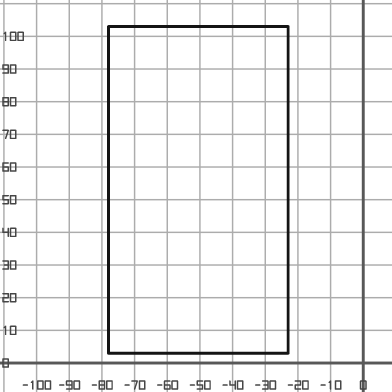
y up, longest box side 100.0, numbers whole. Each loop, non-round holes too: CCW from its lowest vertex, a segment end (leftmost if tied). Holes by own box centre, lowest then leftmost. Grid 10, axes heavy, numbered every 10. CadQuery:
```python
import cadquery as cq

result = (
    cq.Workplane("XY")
    .moveTo(-78.0, 3.0)
    .lineTo(-23.0, 3.0)
    .lineTo(-23.0, 103.0)
    .lineTo(-78.0, 103.0)
    .close()
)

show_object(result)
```